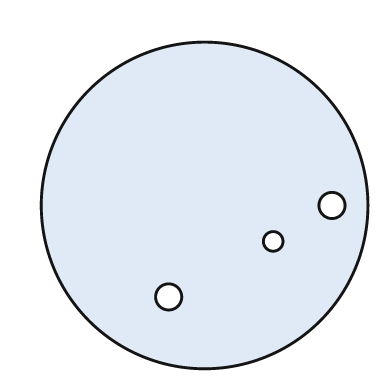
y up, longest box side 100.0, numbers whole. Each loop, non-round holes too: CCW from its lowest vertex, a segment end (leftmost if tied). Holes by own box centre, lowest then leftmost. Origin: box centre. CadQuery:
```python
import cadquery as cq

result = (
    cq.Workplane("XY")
    .moveTo(0.0, 0.0)
    .circle(50.0)
    .moveTo(-11.0, -28.0)
    .circle(4.0)
    .moveTo(21.0, -11.0)
    .circle(3.0)
    .moveTo(39.0, 0.0)
    .circle(4.0)
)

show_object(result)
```